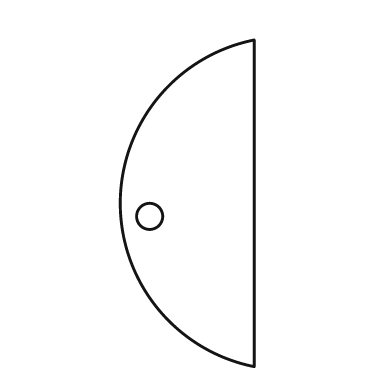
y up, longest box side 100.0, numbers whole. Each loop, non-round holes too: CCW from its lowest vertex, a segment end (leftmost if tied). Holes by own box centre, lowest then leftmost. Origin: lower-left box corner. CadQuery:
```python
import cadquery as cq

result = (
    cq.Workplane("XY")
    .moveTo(41.0, 0.0)
    .lineTo(41.0, 100.0)
    .threePointArc((0.0, 50.0), (41.0, 0.0))
    .close()
    .moveTo(9.0, 46.0)
    .circle(4.0)
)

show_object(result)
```